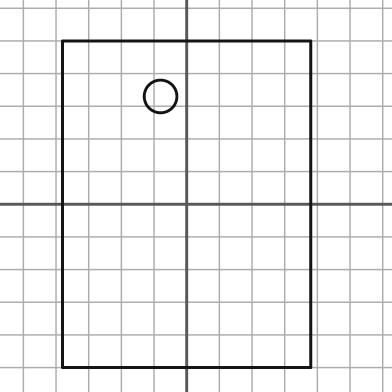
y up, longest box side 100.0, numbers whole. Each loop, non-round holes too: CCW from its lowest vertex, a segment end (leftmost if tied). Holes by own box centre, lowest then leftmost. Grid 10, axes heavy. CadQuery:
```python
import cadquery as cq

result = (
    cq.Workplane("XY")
    .moveTo(-38.0, -50.0)
    .lineTo(38.0, -50.0)
    .lineTo(38.0, 50.0)
    .lineTo(-38.0, 50.0)
    .close()
    .moveTo(-8.0, 33.0)
    .circle(5.0)
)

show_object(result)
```